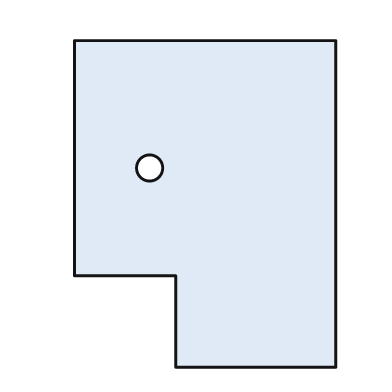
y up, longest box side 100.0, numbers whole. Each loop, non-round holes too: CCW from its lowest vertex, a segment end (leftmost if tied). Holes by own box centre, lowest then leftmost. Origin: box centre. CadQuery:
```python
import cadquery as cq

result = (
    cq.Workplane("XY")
    .moveTo(-9.0, -50.0)
    .lineTo(40.0, -50.0)
    .lineTo(40.0, 50.0)
    .lineTo(-40.0, 50.0)
    .lineTo(-40.0, -22.0)
    .lineTo(-9.0, -22.0)
    .close()
    .moveTo(-17.0, 11.0)
    .circle(4.0)
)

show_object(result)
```